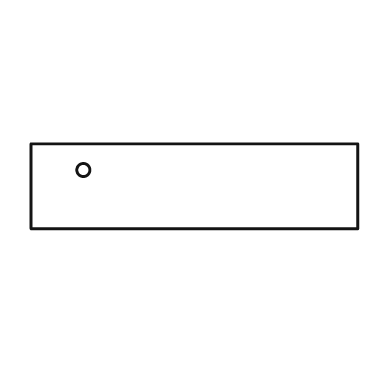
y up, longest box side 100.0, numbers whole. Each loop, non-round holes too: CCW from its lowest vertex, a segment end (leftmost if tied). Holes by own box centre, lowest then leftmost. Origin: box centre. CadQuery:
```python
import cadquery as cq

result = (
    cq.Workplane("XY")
    .moveTo(-50.0, -13.0)
    .lineTo(50.0, -13.0)
    .lineTo(50.0, 13.0)
    .lineTo(-50.0, 13.0)
    .close()
    .moveTo(-34.0, 5.0)
    .circle(2.0)
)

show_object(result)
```